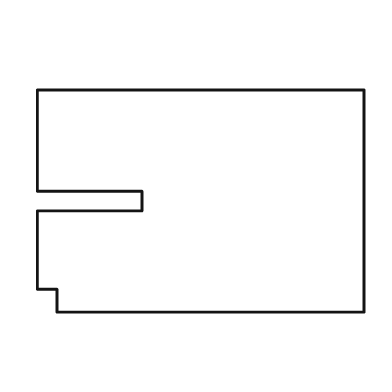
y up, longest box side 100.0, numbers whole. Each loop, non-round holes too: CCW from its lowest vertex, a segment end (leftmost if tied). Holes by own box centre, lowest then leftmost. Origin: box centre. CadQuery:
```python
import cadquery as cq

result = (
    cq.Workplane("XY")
    .moveTo(-44.0, -34.0)
    .lineTo(50.0, -34.0)
    .lineTo(50.0, 34.0)
    .lineTo(-50.0, 34.0)
    .lineTo(-50.0, 3.0)
    .lineTo(-18.0, 3.0)
    .lineTo(-18.0, -3.0)
    .lineTo(-50.0, -3.0)
    .lineTo(-50.0, -27.0)
    .lineTo(-44.0, -27.0)
    .close()
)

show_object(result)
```